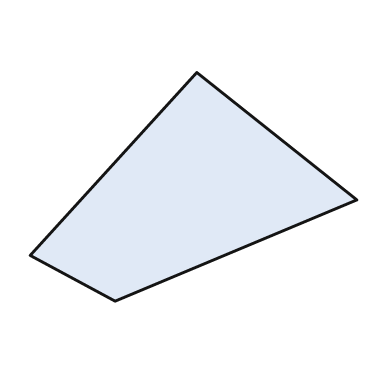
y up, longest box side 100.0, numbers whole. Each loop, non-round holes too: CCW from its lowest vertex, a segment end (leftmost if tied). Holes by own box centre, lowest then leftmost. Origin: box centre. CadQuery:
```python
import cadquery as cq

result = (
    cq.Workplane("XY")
    .moveTo(-24.0, -35.0)
    .lineTo(50.0, -4.0)
    .lineTo(1.0, 35.0)
    .lineTo(-50.0, -21.0)
    .close()
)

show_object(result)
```